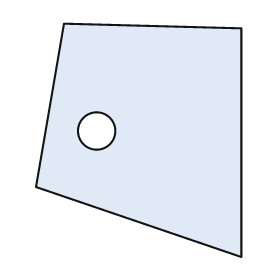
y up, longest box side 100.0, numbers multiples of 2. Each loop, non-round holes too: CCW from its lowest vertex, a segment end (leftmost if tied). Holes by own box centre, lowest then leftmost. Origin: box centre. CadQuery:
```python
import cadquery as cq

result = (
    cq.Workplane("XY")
    .moveTo(44.0, -50.0)
    .lineTo(44.0, 48.0)
    .lineTo(-32.0, 50.0)
    .lineTo(-44.0, -20.0)
    .close()
    .moveTo(-18.0, 4.0)
    .circle(8.0)
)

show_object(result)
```